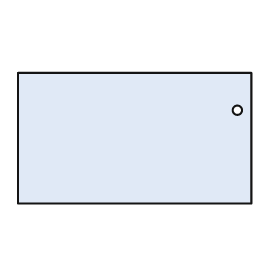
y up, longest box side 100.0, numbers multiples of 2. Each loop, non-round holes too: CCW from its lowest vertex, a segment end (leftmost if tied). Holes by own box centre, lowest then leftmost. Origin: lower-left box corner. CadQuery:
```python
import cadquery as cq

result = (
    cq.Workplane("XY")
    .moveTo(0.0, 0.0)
    .lineTo(100.0, 0.0)
    .lineTo(100.0, 56.0)
    .lineTo(0.0, 56.0)
    .close()
    .moveTo(94.0, 40.0)
    .circle(2.0)
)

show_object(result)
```